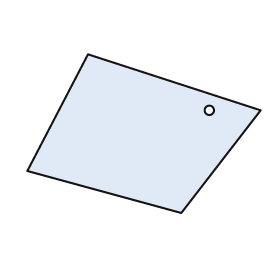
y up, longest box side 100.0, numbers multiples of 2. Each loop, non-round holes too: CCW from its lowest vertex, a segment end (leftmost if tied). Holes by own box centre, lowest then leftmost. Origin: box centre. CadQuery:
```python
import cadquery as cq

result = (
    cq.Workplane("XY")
    .moveTo(16.0, -34.0)
    .lineTo(50.0, 10.0)
    .lineTo(-24.0, 34.0)
    .lineTo(-50.0, -16.0)
    .close()
    .moveTo(28.0, 10.0)
    .circle(2.0)
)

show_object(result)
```